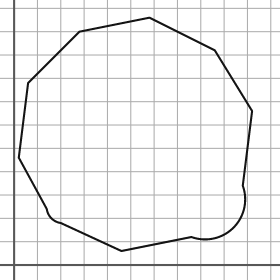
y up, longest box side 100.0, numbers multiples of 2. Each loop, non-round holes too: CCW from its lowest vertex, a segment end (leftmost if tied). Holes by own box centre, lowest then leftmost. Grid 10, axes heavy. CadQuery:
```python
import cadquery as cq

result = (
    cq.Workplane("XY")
    .moveTo(46.0, 6.0)
    .lineTo(76.0, 12.0)
    .threePointArc((94.0, 16.0), (98.0, 34.0))
    .lineTo(102.0, 66.0)
    .lineTo(86.0, 92.0)
    .lineTo(58.0, 106.0)
    .lineTo(28.0, 100.0)
    .lineTo(6.0, 78.0)
    .lineTo(2.0, 46.0)
    .lineTo(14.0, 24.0)
    .threePointArc((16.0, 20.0), (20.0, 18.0))
    .close()
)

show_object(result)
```